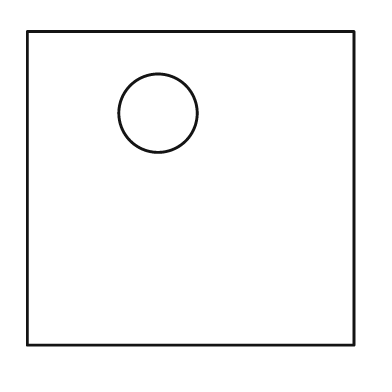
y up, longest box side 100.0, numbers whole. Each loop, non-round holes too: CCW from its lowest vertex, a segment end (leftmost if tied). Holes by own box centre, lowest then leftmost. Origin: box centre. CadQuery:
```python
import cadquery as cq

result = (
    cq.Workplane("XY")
    .moveTo(-50.0, -48.0)
    .lineTo(50.0, -48.0)
    .lineTo(50.0, 48.0)
    .lineTo(-50.0, 48.0)
    .close()
    .moveTo(-10.0, 23.0)
    .circle(12.0)
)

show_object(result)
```